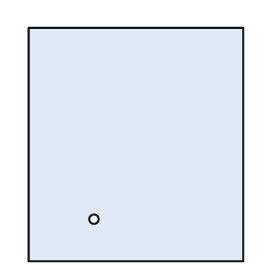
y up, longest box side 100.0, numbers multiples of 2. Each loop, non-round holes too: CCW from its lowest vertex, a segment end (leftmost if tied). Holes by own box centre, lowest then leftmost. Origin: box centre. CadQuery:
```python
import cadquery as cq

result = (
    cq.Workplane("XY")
    .moveTo(-46.0, -50.0)
    .lineTo(46.0, -50.0)
    .lineTo(46.0, 50.0)
    .lineTo(-46.0, 50.0)
    .close()
    .moveTo(-18.0, -32.0)
    .circle(2.0)
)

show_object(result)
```